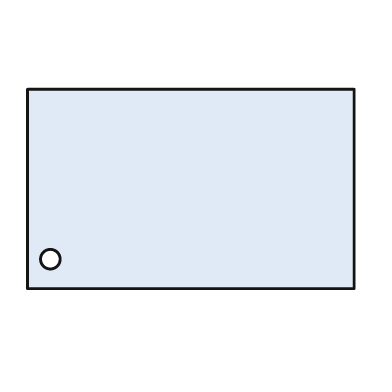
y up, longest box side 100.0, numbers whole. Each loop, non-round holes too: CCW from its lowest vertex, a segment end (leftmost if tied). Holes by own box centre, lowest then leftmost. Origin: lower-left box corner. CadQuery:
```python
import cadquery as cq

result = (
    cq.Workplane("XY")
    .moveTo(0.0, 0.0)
    .lineTo(100.0, 0.0)
    .lineTo(100.0, 61.0)
    .lineTo(0.0, 61.0)
    .close()
    .moveTo(7.0, 9.0)
    .circle(3.0)
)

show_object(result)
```